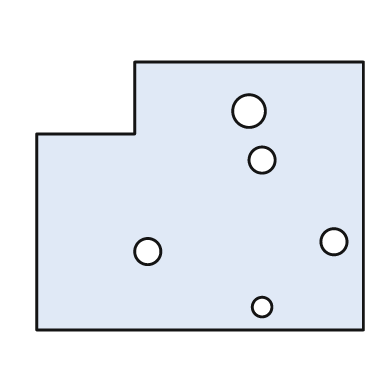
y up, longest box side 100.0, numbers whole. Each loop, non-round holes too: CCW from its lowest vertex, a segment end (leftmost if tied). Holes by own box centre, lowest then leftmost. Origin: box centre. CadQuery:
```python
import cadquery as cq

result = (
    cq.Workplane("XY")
    .moveTo(-50.0, -41.0)
    .lineTo(50.0, -41.0)
    .lineTo(50.0, 41.0)
    .lineTo(-20.0, 41.0)
    .lineTo(-20.0, 19.0)
    .lineTo(-50.0, 19.0)
    .close()
    .moveTo(19.0, -34.0)
    .circle(3.0)
    .moveTo(-16.0, -17.0)
    .circle(4.0)
    .moveTo(41.0, -14.0)
    .circle(4.0)
    .moveTo(19.0, 11.0)
    .circle(4.0)
    .moveTo(15.0, 26.0)
    .circle(5.0)
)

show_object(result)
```